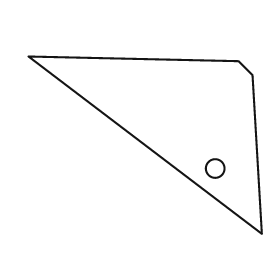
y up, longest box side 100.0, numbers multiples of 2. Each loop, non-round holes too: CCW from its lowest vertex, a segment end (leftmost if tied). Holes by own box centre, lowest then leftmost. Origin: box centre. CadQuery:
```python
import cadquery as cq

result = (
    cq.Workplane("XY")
    .moveTo(50.0, -38.0)
    .lineTo(46.0, 30.0)
    .lineTo(40.0, 36.0)
    .lineTo(-50.0, 38.0)
    .close()
    .moveTo(30.0, -10.0)
    .circle(4.0)
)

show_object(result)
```